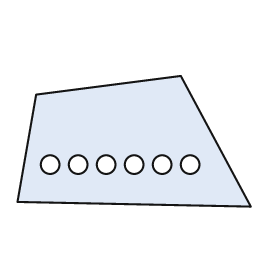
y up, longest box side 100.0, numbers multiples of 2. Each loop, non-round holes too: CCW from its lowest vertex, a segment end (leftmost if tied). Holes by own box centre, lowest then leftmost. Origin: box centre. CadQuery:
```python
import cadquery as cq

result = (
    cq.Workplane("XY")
    .moveTo(50.0, -28.0)
    .lineTo(20.0, 28.0)
    .lineTo(-42.0, 20.0)
    .lineTo(-50.0, -26.0)
    .close()
    .moveTo(-36.0, -10.0)
    .circle(4.0)
    .moveTo(-24.0, -10.0)
    .circle(4.0)
    .moveTo(-12.0, -10.0)
    .circle(4.0)
    .moveTo(0.0, -10.0)
    .circle(4.0)
    .moveTo(12.0, -10.0)
    .circle(4.0)
    .moveTo(24.0, -10.0)
    .circle(4.0)
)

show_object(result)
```